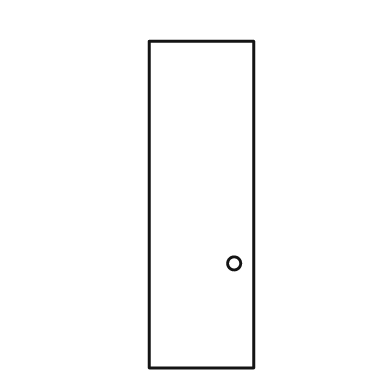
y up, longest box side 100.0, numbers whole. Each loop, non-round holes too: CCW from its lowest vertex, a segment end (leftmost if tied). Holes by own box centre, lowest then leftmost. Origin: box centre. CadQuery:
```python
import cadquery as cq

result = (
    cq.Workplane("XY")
    .moveTo(-16.0, -50.0)
    .lineTo(16.0, -50.0)
    .lineTo(16.0, 50.0)
    .lineTo(-16.0, 50.0)
    .close()
    .moveTo(10.0, -18.0)
    .circle(2.0)
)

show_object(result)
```